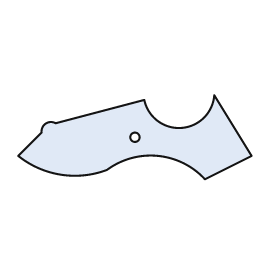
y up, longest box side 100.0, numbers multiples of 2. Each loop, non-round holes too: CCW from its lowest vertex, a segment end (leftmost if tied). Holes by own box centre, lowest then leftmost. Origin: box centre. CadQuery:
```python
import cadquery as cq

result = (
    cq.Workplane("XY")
    .moveTo(30.0, -18.0)
    .lineTo(50.0, -8.0)
    .lineTo(34.0, 18.0)
    .threePointArc((20.0, 4.0), (4.0, 16.0))
    .lineTo(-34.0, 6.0)
    .threePointArc((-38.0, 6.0), (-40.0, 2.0))
    .lineTo(-50.0, -8.0)
    .threePointArc((-32.0, -16.0), (-12.0, -14.0))
    .threePointArc((10.0, -8.0), (30.0, -18.0))
    .close()
    .moveTo(0.0, 0.0)
    .circle(2.0)
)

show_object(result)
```